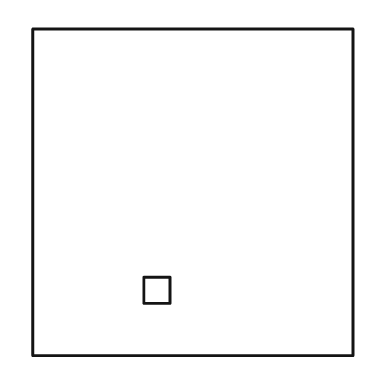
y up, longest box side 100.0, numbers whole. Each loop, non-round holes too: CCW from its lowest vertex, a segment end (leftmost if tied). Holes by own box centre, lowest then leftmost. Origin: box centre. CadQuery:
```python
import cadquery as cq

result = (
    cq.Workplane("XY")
    .moveTo(-49.0, -50.0)
    .lineTo(49.0, -50.0)
    .lineTo(49.0, 50.0)
    .lineTo(-49.0, 50.0)
    .close()
    .moveTo(-15.0, -34.0)
    .lineTo(-7.0, -34.0)
    .lineTo(-7.0, -26.0)
    .lineTo(-15.0, -26.0)
    .close()
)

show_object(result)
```